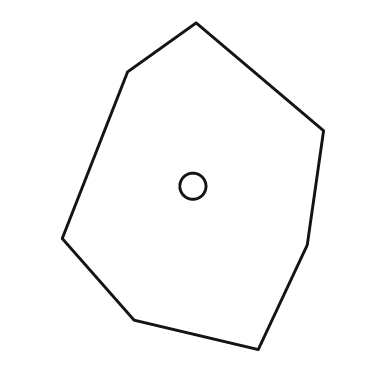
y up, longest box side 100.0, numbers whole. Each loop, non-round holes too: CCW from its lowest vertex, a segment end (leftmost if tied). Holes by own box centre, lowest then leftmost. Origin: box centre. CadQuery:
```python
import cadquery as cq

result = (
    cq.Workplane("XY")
    .moveTo(20.0, -50.0)
    .lineTo(35.0, -18.0)
    .lineTo(40.0, 17.0)
    .lineTo(1.0, 50.0)
    .lineTo(-20.0, 35.0)
    .lineTo(-40.0, -16.0)
    .lineTo(-18.0, -41.0)
    .close()
    .moveTo(0.0, 0.0)
    .circle(4.0)
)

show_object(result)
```